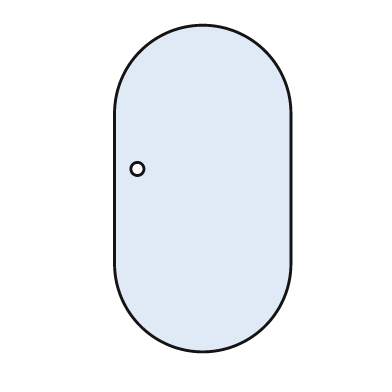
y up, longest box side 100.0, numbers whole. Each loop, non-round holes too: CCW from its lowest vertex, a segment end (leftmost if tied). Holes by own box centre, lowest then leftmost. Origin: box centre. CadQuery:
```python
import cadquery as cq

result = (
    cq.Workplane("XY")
    .moveTo(-27.0, -23.0)
    .threePointArc((0.0, -50.0), (27.0, -23.0))
    .lineTo(27.0, 23.0)
    .threePointArc((0.0, 50.0), (-27.0, 23.0))
    .close()
    .moveTo(-20.0, 6.0)
    .circle(2.0)
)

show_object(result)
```